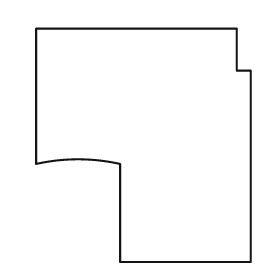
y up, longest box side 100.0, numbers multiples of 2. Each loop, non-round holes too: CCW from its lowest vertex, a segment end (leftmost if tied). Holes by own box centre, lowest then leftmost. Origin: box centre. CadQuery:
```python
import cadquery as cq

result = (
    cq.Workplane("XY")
    .moveTo(-10.0, -50.0)
    .lineTo(46.0, -50.0)
    .lineTo(46.0, 32.0)
    .lineTo(40.0, 32.0)
    .lineTo(40.0, 50.0)
    .lineTo(-46.0, 50.0)
    .lineTo(-46.0, -8.0)
    .threePointArc((-28.0, -6.0), (-10.0, -8.0))
    .close()
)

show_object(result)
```